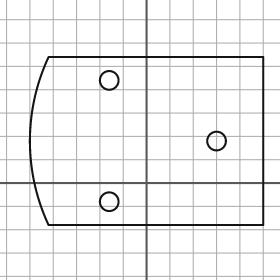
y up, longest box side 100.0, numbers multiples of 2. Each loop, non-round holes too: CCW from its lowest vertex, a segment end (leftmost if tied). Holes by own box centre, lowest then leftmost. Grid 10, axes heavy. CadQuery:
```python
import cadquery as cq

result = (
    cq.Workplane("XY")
    .moveTo(-42.0, -18.0)
    .lineTo(50.0, -18.0)
    .lineTo(50.0, 54.0)
    .lineTo(-42.0, 54.0)
    .threePointArc((-50.0, 18.0), (-42.0, -18.0))
    .close()
    .moveTo(-16.0, -8.0)
    .circle(4.0)
    .moveTo(30.0, 18.0)
    .circle(4.0)
    .moveTo(-16.0, 44.0)
    .circle(4.0)
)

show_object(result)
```